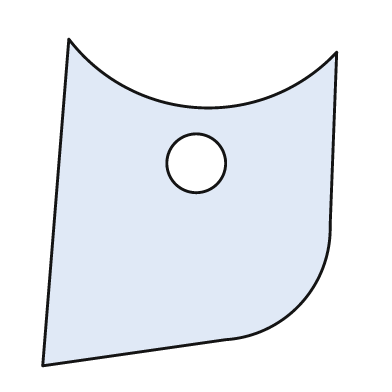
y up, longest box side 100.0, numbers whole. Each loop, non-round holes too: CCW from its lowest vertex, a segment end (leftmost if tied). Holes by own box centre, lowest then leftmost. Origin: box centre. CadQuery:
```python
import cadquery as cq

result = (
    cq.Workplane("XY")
    .moveTo(-45.0, -50.0)
    .lineTo(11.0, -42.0)
    .threePointArc((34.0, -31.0), (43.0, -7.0))
    .lineTo(45.0, 46.0)
    .threePointArc((3.0, 29.0), (-37.0, 50.0))
    .close()
    .moveTo(2.0, 12.0)
    .circle(9.0)
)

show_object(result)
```